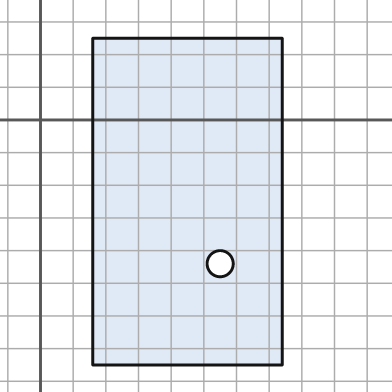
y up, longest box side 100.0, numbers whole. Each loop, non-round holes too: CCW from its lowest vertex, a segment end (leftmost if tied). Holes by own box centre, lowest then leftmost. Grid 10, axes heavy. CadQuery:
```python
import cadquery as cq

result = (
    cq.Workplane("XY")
    .moveTo(16.0, -75.0)
    .lineTo(74.0, -75.0)
    .lineTo(74.0, 25.0)
    .lineTo(16.0, 25.0)
    .close()
    .moveTo(55.0, -44.0)
    .circle(4.0)
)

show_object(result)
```